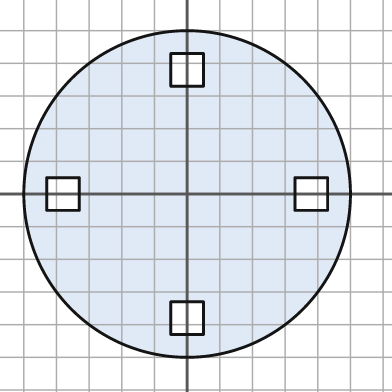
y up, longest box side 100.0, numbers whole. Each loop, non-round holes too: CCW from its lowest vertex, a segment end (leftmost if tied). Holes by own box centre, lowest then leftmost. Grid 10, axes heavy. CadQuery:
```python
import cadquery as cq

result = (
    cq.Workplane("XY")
    .moveTo(0.0, 0.0)
    .circle(50.0)
    .moveTo(-5.0, -43.0)
    .lineTo(5.0, -43.0)
    .lineTo(5.0, -33.0)
    .lineTo(-5.0, -33.0)
    .close()
    .moveTo(-43.0, -5.0)
    .lineTo(-33.0, -5.0)
    .lineTo(-33.0, 5.0)
    .lineTo(-43.0, 5.0)
    .close()
    .moveTo(33.0, -5.0)
    .lineTo(43.0, -5.0)
    .lineTo(43.0, 5.0)
    .lineTo(33.0, 5.0)
    .close()
    .moveTo(-5.0, 33.0)
    .lineTo(5.0, 33.0)
    .lineTo(5.0, 43.0)
    .lineTo(-5.0, 43.0)
    .close()
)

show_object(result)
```